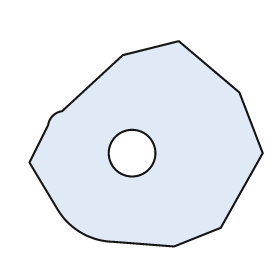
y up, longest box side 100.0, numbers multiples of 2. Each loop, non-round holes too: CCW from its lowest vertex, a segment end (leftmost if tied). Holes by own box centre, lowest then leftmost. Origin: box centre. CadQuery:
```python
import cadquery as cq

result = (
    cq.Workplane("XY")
    .moveTo(12.0, -44.0)
    .lineTo(32.0, -36.0)
    .lineTo(50.0, -4.0)
    .lineTo(40.0, 22.0)
    .lineTo(14.0, 44.0)
    .lineTo(-10.0, 38.0)
    .lineTo(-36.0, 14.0)
    .threePointArc((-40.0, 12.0), (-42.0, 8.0))
    .lineTo(-50.0, -8.0)
    .lineTo(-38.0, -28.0)
    .threePointArc((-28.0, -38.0), (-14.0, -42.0))
    .close()
    .moveTo(-6.0, -4.0)
    .circle(10.0)
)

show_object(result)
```